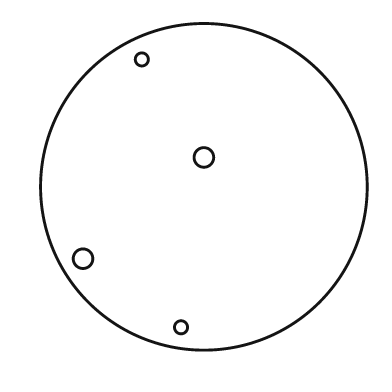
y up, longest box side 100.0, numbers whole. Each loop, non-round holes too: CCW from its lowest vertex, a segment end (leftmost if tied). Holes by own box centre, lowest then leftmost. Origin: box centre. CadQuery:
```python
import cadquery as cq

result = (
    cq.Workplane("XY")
    .moveTo(0.0, 0.0)
    .circle(50.0)
    .moveTo(-7.0, -43.0)
    .circle(2.0)
    .moveTo(-37.0, -22.0)
    .circle(3.0)
    .moveTo(0.0, 9.0)
    .circle(3.0)
    .moveTo(-19.0, 39.0)
    .circle(2.0)
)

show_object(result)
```